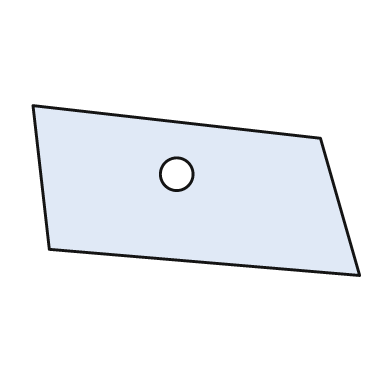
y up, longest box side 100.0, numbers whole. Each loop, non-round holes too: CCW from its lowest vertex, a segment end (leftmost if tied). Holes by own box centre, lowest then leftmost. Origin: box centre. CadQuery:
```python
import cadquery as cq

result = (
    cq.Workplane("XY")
    .moveTo(50.0, -26.0)
    .lineTo(38.0, 16.0)
    .lineTo(-50.0, 26.0)
    .lineTo(-45.0, -18.0)
    .close()
    .moveTo(-6.0, 5.0)
    .circle(5.0)
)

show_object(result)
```